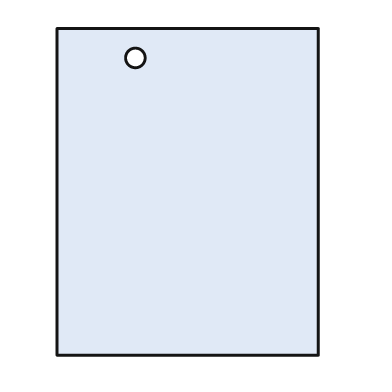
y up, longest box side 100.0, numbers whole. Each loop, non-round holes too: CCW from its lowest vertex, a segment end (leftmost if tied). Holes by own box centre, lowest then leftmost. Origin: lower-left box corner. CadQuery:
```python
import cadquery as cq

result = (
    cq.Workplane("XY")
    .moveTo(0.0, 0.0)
    .lineTo(80.0, 0.0)
    .lineTo(80.0, 100.0)
    .lineTo(0.0, 100.0)
    .close()
    .moveTo(24.0, 91.0)
    .circle(3.0)
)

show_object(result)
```